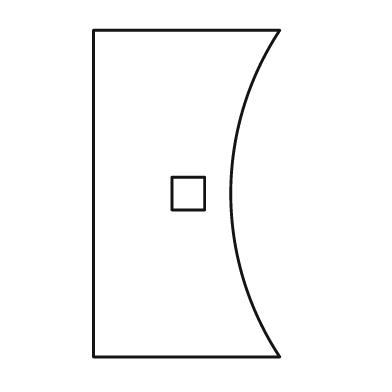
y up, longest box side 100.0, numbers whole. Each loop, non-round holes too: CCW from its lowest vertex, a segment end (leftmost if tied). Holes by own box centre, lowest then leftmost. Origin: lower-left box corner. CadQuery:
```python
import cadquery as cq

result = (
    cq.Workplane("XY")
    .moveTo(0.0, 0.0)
    .lineTo(57.0, 0.0)
    .threePointArc((42.0, 50.0), (57.0, 100.0))
    .lineTo(0.0, 100.0)
    .close()
    .moveTo(24.0, 45.0)
    .lineTo(34.0, 45.0)
    .lineTo(34.0, 55.0)
    .lineTo(24.0, 55.0)
    .close()
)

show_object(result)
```